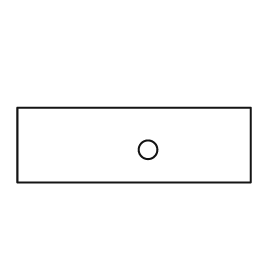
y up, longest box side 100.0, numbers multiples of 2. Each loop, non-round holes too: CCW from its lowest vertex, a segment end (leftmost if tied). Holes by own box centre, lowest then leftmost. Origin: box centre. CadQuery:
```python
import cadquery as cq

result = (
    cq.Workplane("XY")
    .moveTo(-50.0, -16.0)
    .lineTo(50.0, -16.0)
    .lineTo(50.0, 16.0)
    .lineTo(-50.0, 16.0)
    .close()
    .moveTo(6.0, -2.0)
    .circle(4.0)
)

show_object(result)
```